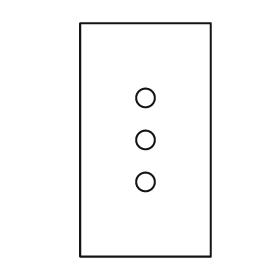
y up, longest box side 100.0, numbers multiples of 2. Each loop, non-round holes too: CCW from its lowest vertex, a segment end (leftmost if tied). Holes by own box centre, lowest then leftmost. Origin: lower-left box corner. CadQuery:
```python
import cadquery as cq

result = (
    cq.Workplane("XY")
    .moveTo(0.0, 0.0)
    .lineTo(56.0, 0.0)
    .lineTo(56.0, 100.0)
    .lineTo(0.0, 100.0)
    .close()
    .moveTo(28.0, 32.0)
    .circle(4.0)
    .moveTo(28.0, 50.0)
    .circle(4.0)
    .moveTo(28.0, 68.0)
    .circle(4.0)
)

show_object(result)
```